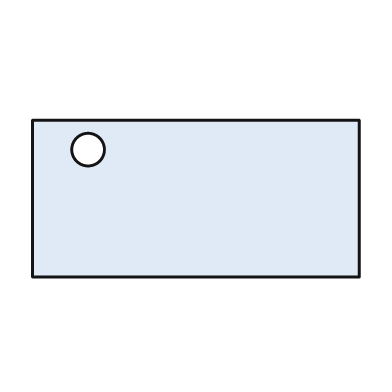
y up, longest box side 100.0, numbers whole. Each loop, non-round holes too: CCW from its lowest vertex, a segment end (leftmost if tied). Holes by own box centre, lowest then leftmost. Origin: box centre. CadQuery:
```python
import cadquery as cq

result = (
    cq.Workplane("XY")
    .moveTo(-50.0, -24.0)
    .lineTo(50.0, -24.0)
    .lineTo(50.0, 24.0)
    .lineTo(-50.0, 24.0)
    .close()
    .moveTo(-33.0, 15.0)
    .circle(5.0)
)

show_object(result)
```